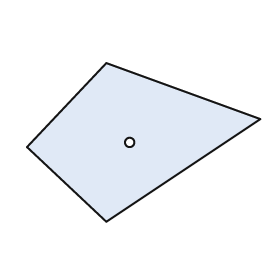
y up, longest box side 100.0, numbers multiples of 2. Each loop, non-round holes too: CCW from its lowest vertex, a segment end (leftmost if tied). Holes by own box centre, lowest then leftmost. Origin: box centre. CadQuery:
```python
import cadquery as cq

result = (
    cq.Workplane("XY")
    .moveTo(-16.0, -34.0)
    .lineTo(50.0, 10.0)
    .lineTo(-16.0, 34.0)
    .lineTo(-50.0, -2.0)
    .close()
    .moveTo(-6.0, 0.0)
    .circle(2.0)
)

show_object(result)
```